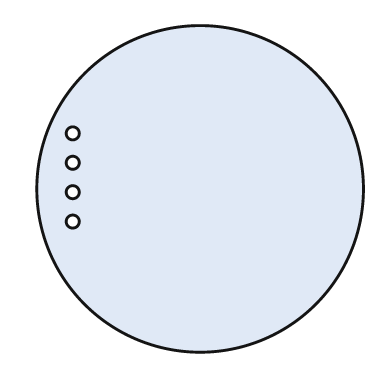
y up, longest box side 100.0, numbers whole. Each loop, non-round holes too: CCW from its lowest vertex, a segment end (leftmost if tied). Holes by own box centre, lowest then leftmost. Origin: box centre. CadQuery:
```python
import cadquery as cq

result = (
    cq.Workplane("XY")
    .moveTo(0.0, 0.0)
    .circle(50.0)
    .moveTo(-39.0, -10.0)
    .circle(2.0)
    .moveTo(-39.0, -1.0)
    .circle(2.0)
    .moveTo(-39.0, 8.0)
    .circle(2.0)
    .moveTo(-39.0, 17.0)
    .circle(2.0)
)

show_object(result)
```